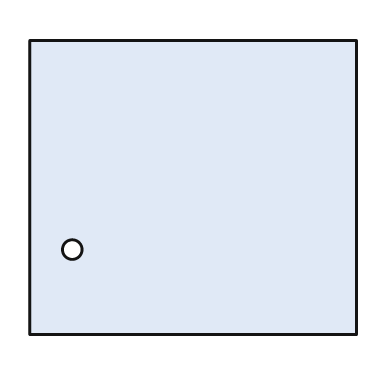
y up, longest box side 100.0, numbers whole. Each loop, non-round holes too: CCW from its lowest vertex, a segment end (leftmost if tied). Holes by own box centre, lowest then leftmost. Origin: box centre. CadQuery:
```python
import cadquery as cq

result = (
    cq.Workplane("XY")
    .moveTo(-50.0, -45.0)
    .lineTo(50.0, -45.0)
    .lineTo(50.0, 45.0)
    .lineTo(-50.0, 45.0)
    .close()
    .moveTo(-37.0, -19.0)
    .circle(3.0)
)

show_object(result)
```